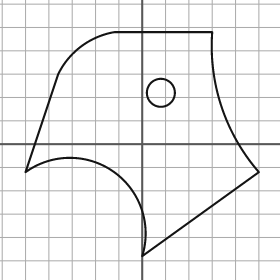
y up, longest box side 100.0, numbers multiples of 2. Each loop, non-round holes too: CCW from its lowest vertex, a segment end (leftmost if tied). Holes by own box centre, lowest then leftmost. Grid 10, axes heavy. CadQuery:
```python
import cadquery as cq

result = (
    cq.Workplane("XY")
    .moveTo(0.0, -48.0)
    .lineTo(50.0, -12.0)
    .threePointArc((34.0, 16.0), (30.0, 48.0))
    .lineTo(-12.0, 48.0)
    .threePointArc((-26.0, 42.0), (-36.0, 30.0))
    .lineTo(-50.0, -12.0)
    .threePointArc((-12.0, -12.0), (0.0, -48.0))
    .close()
    .moveTo(8.0, 22.0)
    .circle(6.0)
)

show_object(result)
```